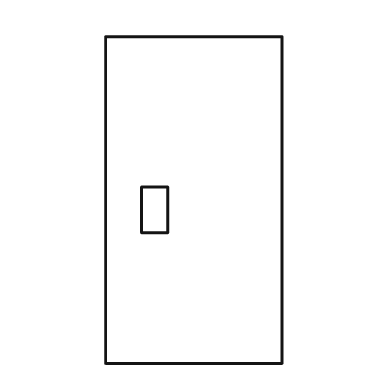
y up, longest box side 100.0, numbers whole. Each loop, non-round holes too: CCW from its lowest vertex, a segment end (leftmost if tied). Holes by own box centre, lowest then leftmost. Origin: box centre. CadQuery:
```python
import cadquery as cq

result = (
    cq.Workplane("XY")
    .moveTo(-27.0, -50.0)
    .lineTo(27.0, -50.0)
    .lineTo(27.0, 50.0)
    .lineTo(-27.0, 50.0)
    .close()
    .moveTo(-16.0, -10.0)
    .lineTo(-8.0, -10.0)
    .lineTo(-8.0, 4.0)
    .lineTo(-16.0, 4.0)
    .close()
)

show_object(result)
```